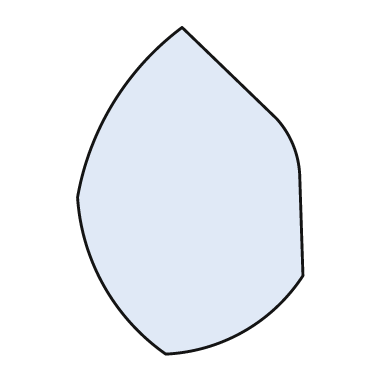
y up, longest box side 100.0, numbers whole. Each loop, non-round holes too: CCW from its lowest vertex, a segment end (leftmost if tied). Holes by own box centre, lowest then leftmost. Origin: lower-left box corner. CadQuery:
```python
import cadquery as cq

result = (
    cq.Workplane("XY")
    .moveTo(27.0, 0.0)
    .threePointArc((51.0, 7.0), (69.0, 24.0))
    .lineTo(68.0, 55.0)
    .threePointArc((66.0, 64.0), (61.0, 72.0))
    .lineTo(32.0, 100.0)
    .threePointArc((11.0, 77.0), (0.0, 48.0))
    .threePointArc((8.0, 21.0), (27.0, 0.0))
    .close()
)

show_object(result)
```